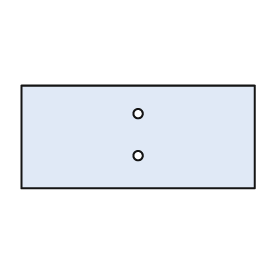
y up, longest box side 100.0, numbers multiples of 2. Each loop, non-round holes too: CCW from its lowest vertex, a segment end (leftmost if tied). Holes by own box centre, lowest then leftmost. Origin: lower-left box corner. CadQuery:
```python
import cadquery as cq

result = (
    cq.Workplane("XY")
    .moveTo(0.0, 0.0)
    .lineTo(100.0, 0.0)
    .lineTo(100.0, 44.0)
    .lineTo(0.0, 44.0)
    .close()
    .moveTo(50.0, 14.0)
    .circle(2.0)
    .moveTo(50.0, 32.0)
    .circle(2.0)
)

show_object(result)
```